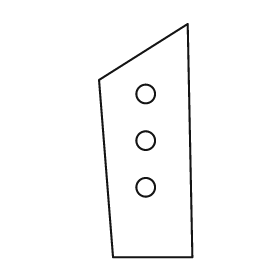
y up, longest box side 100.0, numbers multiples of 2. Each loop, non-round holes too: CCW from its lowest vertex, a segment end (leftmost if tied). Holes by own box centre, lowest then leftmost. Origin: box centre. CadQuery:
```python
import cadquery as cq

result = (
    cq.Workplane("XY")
    .moveTo(-14.0, -50.0)
    .lineTo(20.0, -50.0)
    .lineTo(18.0, 50.0)
    .lineTo(-20.0, 26.0)
    .close()
    .moveTo(0.0, -20.0)
    .circle(4.0)
    .moveTo(0.0, 0.0)
    .circle(4.0)
    .moveTo(0.0, 20.0)
    .circle(4.0)
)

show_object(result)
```